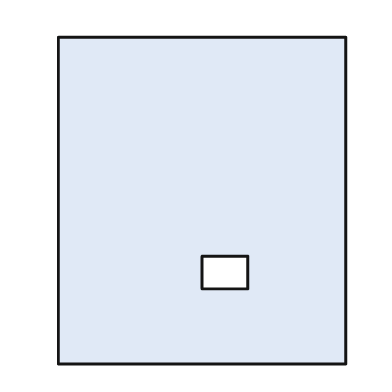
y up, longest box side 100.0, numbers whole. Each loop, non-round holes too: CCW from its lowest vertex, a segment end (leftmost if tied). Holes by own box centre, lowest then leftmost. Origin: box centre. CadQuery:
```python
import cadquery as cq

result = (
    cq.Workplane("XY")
    .moveTo(-44.0, -50.0)
    .lineTo(44.0, -50.0)
    .lineTo(44.0, 50.0)
    .lineTo(-44.0, 50.0)
    .close()
    .moveTo(0.0, -27.0)
    .lineTo(14.0, -27.0)
    .lineTo(14.0, -17.0)
    .lineTo(0.0, -17.0)
    .close()
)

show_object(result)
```